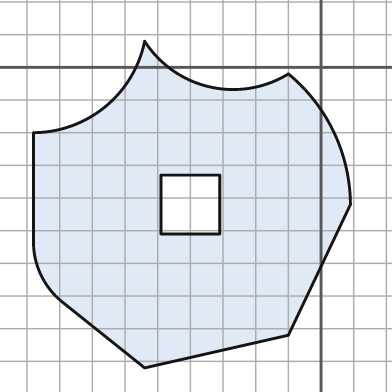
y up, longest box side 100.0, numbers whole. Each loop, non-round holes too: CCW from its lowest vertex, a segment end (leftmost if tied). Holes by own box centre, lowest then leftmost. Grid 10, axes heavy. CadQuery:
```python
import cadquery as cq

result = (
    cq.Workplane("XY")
    .moveTo(-54.0, -92.0)
    .lineTo(-10.0, -82.0)
    .lineTo(9.0, -42.0)
    .threePointArc((4.0, -20.0), (-10.0, -2.0))
    .threePointArc((-34.0, -6.0), (-54.0, 8.0))
    .threePointArc((-66.0, -12.0), (-88.0, -20.0))
    .lineTo(-88.0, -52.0)
    .threePointArc((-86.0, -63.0), (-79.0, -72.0))
    .close()
    .moveTo(-49.0, -51.0)
    .lineTo(-31.0, -51.0)
    .lineTo(-31.0, -33.0)
    .lineTo(-49.0, -33.0)
    .close()
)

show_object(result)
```